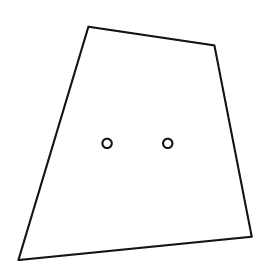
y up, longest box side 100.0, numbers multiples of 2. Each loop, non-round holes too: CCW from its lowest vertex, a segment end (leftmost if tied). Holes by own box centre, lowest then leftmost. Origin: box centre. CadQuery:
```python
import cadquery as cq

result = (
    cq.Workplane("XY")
    .moveTo(-50.0, -50.0)
    .lineTo(50.0, -40.0)
    .lineTo(34.0, 42.0)
    .lineTo(-20.0, 50.0)
    .close()
    .moveTo(-12.0, 0.0)
    .circle(2.0)
    .moveTo(14.0, 0.0)
    .circle(2.0)
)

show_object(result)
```